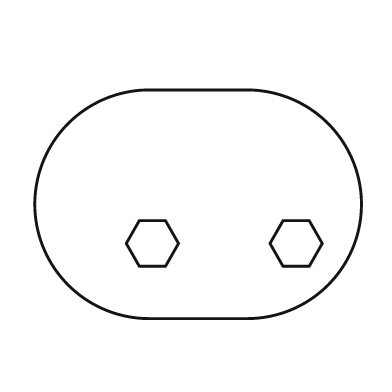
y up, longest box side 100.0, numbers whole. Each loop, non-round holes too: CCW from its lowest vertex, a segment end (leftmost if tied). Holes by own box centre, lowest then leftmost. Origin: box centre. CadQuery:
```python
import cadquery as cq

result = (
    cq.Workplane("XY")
    .moveTo(-15.0, -35.0)
    .lineTo(15.0, -35.0)
    .threePointArc((50.0, 0.0), (15.0, 35.0))
    .lineTo(-15.0, 35.0)
    .threePointArc((-50.0, 0.0), (-15.0, -35.0))
    .close()
    .moveTo(-18.0, -19.0)
    .lineTo(-10.0, -19.0)
    .lineTo(-6.0, -12.0)
    .lineTo(-10.0, -5.0)
    .lineTo(-18.0, -5.0)
    .lineTo(-22.0, -12.0)
    .close()
    .moveTo(26.0, -19.0)
    .lineTo(34.0, -19.0)
    .lineTo(38.0, -12.0)
    .lineTo(34.0, -5.0)
    .lineTo(26.0, -5.0)
    .lineTo(22.0, -12.0)
    .close()
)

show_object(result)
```